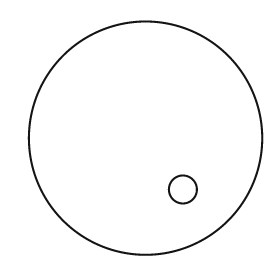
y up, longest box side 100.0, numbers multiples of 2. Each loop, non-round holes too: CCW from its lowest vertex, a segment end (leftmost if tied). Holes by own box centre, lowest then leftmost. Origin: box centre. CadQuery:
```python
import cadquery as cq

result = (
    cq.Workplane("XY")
    .moveTo(0.0, 0.0)
    .circle(50.0)
    .moveTo(16.0, -22.0)
    .circle(6.0)
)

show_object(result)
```